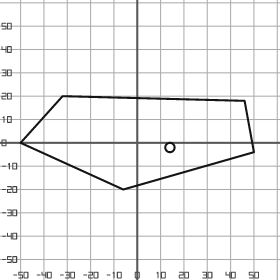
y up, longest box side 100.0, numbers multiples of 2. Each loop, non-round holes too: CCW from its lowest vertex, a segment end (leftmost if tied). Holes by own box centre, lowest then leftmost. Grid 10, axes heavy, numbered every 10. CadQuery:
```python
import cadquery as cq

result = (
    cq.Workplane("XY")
    .moveTo(-6.0, -20.0)
    .lineTo(50.0, -4.0)
    .lineTo(46.0, 18.0)
    .lineTo(-32.0, 20.0)
    .lineTo(-50.0, 0.0)
    .close()
    .moveTo(14.0, -2.0)
    .circle(2.0)
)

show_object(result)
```